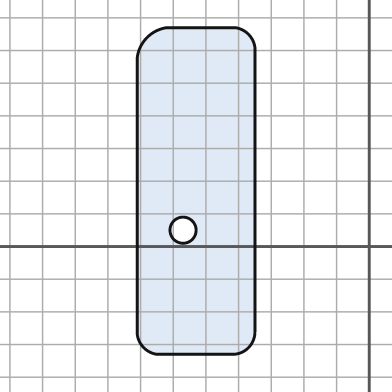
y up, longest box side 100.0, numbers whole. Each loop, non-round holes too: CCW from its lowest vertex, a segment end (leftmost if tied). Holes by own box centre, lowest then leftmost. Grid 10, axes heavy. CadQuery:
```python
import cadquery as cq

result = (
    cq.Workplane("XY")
    .moveTo(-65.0, -33.0)
    .lineTo(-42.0, -33.0)
    .threePointArc((-37.0, -31.0), (-35.0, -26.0))
    .lineTo(-35.0, 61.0)
    .threePointArc((-37.0, 65.0), (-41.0, 67.0))
    .lineTo(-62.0, 67.0)
    .threePointArc((-68.0, 64.0), (-71.0, 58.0))
    .lineTo(-71.0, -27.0)
    .threePointArc((-69.0, -31.0), (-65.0, -33.0))
    .close()
    .moveTo(-57.0, 5.0)
    .circle(4.0)
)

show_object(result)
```